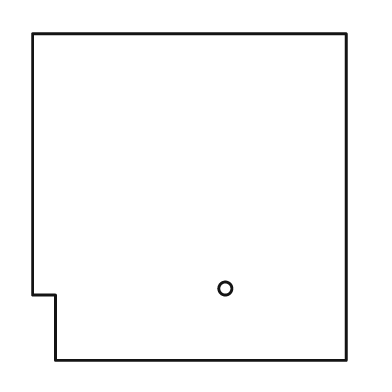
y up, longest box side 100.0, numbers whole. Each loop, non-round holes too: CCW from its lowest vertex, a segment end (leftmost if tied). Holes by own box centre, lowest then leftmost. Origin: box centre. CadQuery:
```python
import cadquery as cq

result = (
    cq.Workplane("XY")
    .moveTo(-41.0, -50.0)
    .lineTo(48.0, -50.0)
    .lineTo(48.0, 50.0)
    .lineTo(-48.0, 50.0)
    .lineTo(-48.0, -30.0)
    .lineTo(-41.0, -30.0)
    .close()
    .moveTo(11.0, -28.0)
    .circle(2.0)
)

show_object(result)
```